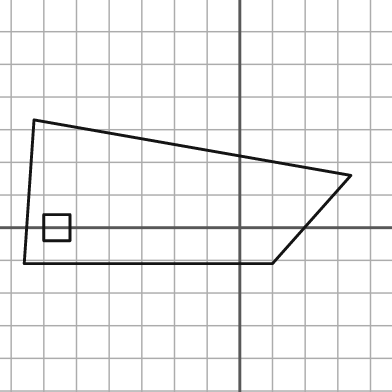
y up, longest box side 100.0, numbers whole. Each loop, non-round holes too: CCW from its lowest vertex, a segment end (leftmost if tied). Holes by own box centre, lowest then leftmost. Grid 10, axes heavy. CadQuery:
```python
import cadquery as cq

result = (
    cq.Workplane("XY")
    .moveTo(-66.0, -11.0)
    .lineTo(10.0, -11.0)
    .lineTo(34.0, 16.0)
    .lineTo(-63.0, 33.0)
    .close()
    .moveTo(-60.0, -4.0)
    .lineTo(-52.0, -4.0)
    .lineTo(-52.0, 4.0)
    .lineTo(-60.0, 4.0)
    .close()
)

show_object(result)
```